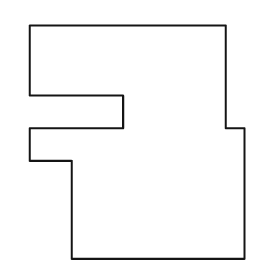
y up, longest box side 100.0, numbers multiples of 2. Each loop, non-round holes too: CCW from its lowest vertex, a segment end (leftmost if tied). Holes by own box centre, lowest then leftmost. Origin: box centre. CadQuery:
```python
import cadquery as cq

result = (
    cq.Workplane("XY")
    .moveTo(-28.0, -50.0)
    .lineTo(46.0, -50.0)
    .lineTo(46.0, 6.0)
    .lineTo(38.0, 6.0)
    .lineTo(38.0, 50.0)
    .lineTo(-46.0, 50.0)
    .lineTo(-46.0, 20.0)
    .lineTo(-6.0, 20.0)
    .lineTo(-6.0, 6.0)
    .lineTo(-46.0, 6.0)
    .lineTo(-46.0, -8.0)
    .lineTo(-28.0, -8.0)
    .close()
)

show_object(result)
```